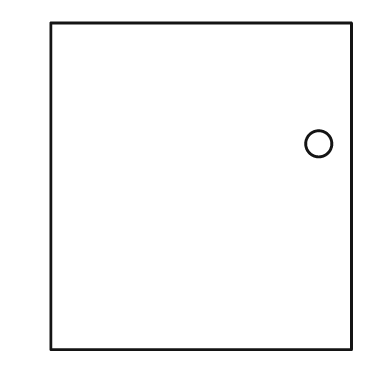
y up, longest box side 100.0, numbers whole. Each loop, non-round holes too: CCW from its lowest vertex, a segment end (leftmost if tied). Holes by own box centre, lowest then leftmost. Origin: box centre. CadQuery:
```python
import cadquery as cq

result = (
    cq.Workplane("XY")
    .moveTo(-46.0, -50.0)
    .lineTo(46.0, -50.0)
    .lineTo(46.0, 50.0)
    .lineTo(-46.0, 50.0)
    .close()
    .moveTo(36.0, 13.0)
    .circle(4.0)
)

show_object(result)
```